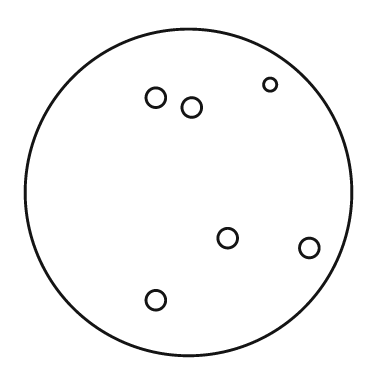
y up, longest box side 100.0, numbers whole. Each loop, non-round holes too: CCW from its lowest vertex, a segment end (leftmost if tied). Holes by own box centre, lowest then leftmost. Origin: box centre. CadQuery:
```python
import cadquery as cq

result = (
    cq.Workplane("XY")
    .moveTo(0.0, 0.0)
    .circle(50.0)
    .moveTo(-10.0, -33.0)
    .circle(3.0)
    .moveTo(37.0, -17.0)
    .circle(3.0)
    .moveTo(12.0, -14.0)
    .circle(3.0)
    .moveTo(1.0, 26.0)
    .circle(3.0)
    .moveTo(-10.0, 29.0)
    .circle(3.0)
    .moveTo(25.0, 33.0)
    .circle(2.0)
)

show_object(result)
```